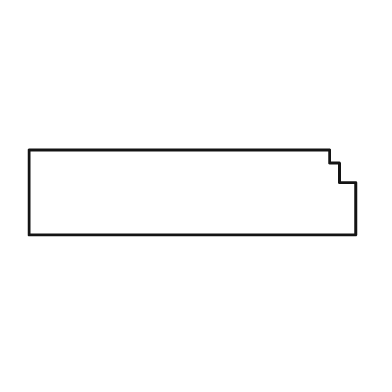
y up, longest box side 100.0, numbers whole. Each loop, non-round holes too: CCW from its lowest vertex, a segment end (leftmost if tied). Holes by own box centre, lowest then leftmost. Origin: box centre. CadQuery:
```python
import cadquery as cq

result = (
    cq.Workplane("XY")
    .moveTo(-50.0, -13.0)
    .lineTo(50.0, -13.0)
    .lineTo(50.0, 3.0)
    .lineTo(45.0, 3.0)
    .lineTo(45.0, 9.0)
    .lineTo(42.0, 9.0)
    .lineTo(42.0, 13.0)
    .lineTo(-50.0, 13.0)
    .close()
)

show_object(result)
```